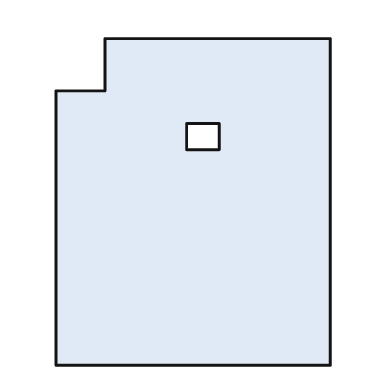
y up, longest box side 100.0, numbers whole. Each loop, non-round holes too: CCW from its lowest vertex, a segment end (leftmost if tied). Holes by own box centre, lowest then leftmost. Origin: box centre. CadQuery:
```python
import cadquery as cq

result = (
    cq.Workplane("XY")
    .moveTo(-42.0, -50.0)
    .lineTo(42.0, -50.0)
    .lineTo(42.0, 50.0)
    .lineTo(-27.0, 50.0)
    .lineTo(-27.0, 34.0)
    .lineTo(-42.0, 34.0)
    .close()
    .moveTo(-2.0, 16.0)
    .lineTo(8.0, 16.0)
    .lineTo(8.0, 24.0)
    .lineTo(-2.0, 24.0)
    .close()
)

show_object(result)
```